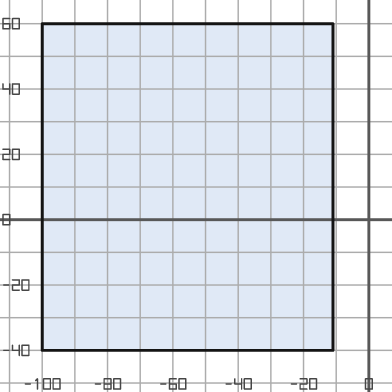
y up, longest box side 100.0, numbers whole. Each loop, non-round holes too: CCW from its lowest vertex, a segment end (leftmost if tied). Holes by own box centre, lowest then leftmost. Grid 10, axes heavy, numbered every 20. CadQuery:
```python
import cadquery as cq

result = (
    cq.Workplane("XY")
    .moveTo(-100.0, -40.0)
    .lineTo(-11.0, -40.0)
    .lineTo(-11.0, 60.0)
    .lineTo(-100.0, 60.0)
    .close()
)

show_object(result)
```